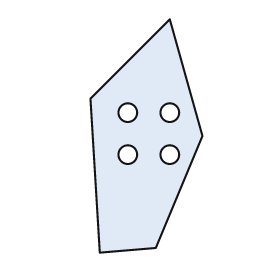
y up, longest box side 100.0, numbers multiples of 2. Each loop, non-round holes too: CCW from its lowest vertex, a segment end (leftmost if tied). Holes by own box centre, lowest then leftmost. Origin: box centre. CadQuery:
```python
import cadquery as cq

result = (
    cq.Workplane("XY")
    .moveTo(-20.0, -50.0)
    .lineTo(4.0, -48.0)
    .lineTo(24.0, 0.0)
    .lineTo(10.0, 50.0)
    .lineTo(-24.0, 16.0)
    .close()
    .moveTo(-8.0, -8.0)
    .circle(4.0)
    .moveTo(10.0, -8.0)
    .circle(4.0)
    .moveTo(-8.0, 10.0)
    .circle(4.0)
    .moveTo(10.0, 10.0)
    .circle(4.0)
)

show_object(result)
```